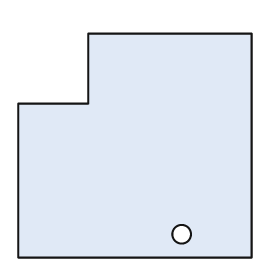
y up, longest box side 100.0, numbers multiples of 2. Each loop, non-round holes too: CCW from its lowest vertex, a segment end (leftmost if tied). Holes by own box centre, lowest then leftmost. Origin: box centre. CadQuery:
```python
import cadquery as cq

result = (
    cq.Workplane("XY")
    .moveTo(-50.0, -48.0)
    .lineTo(50.0, -48.0)
    .lineTo(50.0, 48.0)
    .lineTo(-20.0, 48.0)
    .lineTo(-20.0, 18.0)
    .lineTo(-50.0, 18.0)
    .close()
    .moveTo(20.0, -38.0)
    .circle(4.0)
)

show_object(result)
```